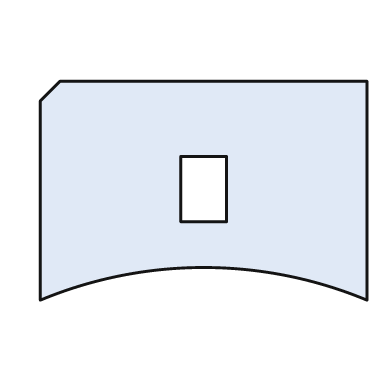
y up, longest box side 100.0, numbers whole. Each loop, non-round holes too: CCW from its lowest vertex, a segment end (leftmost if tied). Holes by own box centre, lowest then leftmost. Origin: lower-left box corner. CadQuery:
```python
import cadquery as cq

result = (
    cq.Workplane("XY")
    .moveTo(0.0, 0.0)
    .threePointArc((50.0, 10.0), (100.0, 0.0))
    .lineTo(100.0, 67.0)
    .lineTo(6.0, 67.0)
    .lineTo(0.0, 61.0)
    .close()
    .moveTo(43.0, 24.0)
    .lineTo(57.0, 24.0)
    .lineTo(57.0, 44.0)
    .lineTo(43.0, 44.0)
    .close()
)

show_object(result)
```